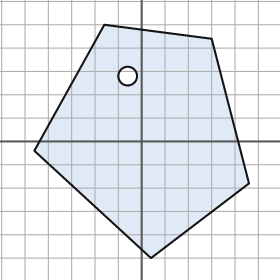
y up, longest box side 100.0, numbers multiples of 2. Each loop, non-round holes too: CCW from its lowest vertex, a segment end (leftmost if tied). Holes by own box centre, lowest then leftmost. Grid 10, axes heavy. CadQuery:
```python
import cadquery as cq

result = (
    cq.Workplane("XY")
    .moveTo(4.0, -50.0)
    .lineTo(46.0, -18.0)
    .lineTo(30.0, 44.0)
    .lineTo(-16.0, 50.0)
    .lineTo(-46.0, -4.0)
    .close()
    .moveTo(-6.0, 28.0)
    .circle(4.0)
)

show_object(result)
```